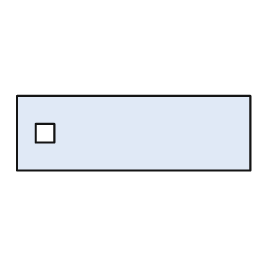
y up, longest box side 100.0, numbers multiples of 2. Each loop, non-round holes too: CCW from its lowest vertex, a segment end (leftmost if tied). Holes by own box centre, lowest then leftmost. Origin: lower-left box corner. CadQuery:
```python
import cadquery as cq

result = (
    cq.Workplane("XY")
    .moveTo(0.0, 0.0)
    .lineTo(100.0, 0.0)
    .lineTo(100.0, 32.0)
    .lineTo(0.0, 32.0)
    .close()
    .moveTo(8.0, 12.0)
    .lineTo(16.0, 12.0)
    .lineTo(16.0, 20.0)
    .lineTo(8.0, 20.0)
    .close()
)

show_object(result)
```